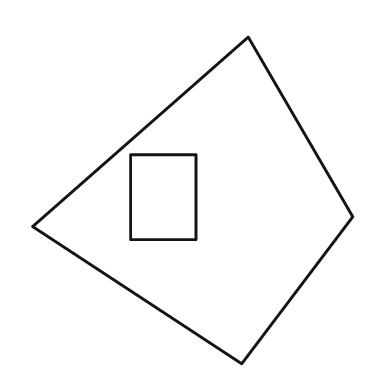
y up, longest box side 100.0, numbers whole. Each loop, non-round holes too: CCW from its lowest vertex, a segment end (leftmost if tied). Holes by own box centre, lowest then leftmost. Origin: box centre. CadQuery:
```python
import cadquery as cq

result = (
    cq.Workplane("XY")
    .moveTo(15.0, -50.0)
    .lineTo(49.0, -5.0)
    .lineTo(17.0, 50.0)
    .lineTo(-49.0, -8.0)
    .close()
    .moveTo(-19.0, -12.0)
    .lineTo(1.0, -12.0)
    .lineTo(1.0, 14.0)
    .lineTo(-19.0, 14.0)
    .close()
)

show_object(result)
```